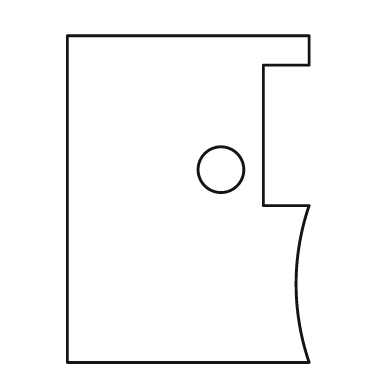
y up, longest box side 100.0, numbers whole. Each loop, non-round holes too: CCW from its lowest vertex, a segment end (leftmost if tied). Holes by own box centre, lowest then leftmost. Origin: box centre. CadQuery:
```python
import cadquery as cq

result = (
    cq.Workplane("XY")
    .moveTo(-37.0, -50.0)
    .lineTo(37.0, -50.0)
    .threePointArc((33.0, -26.0), (37.0, -2.0))
    .lineTo(23.0, -2.0)
    .lineTo(23.0, 41.0)
    .lineTo(37.0, 41.0)
    .lineTo(37.0, 50.0)
    .lineTo(-37.0, 50.0)
    .close()
    .moveTo(10.0, 9.0)
    .circle(7.0)
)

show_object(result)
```